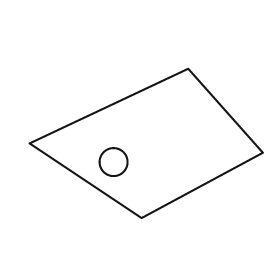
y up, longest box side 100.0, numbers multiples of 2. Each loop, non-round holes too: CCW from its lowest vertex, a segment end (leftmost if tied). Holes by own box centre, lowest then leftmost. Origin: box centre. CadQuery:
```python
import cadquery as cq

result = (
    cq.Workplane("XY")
    .moveTo(-2.0, -32.0)
    .lineTo(50.0, -4.0)
    .lineTo(18.0, 32.0)
    .lineTo(-50.0, 0.0)
    .close()
    .moveTo(-14.0, -8.0)
    .circle(6.0)
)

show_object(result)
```